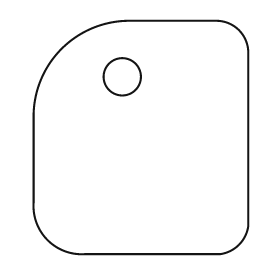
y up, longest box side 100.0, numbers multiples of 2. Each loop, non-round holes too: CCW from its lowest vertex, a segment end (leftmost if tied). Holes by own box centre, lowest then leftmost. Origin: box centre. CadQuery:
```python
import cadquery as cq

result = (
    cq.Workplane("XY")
    .moveTo(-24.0, -50.0)
    .lineTo(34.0, -50.0)
    .threePointArc((42.0, -46.0), (46.0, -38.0))
    .lineTo(46.0, 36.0)
    .threePointArc((42.0, 46.0), (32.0, 50.0))
    .lineTo(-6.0, 50.0)
    .threePointArc((-34.0, 38.0), (-46.0, 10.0))
    .lineTo(-46.0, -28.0)
    .threePointArc((-40.0, -44.0), (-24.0, -50.0))
    .close()
    .moveTo(-8.0, 26.0)
    .circle(8.0)
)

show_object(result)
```